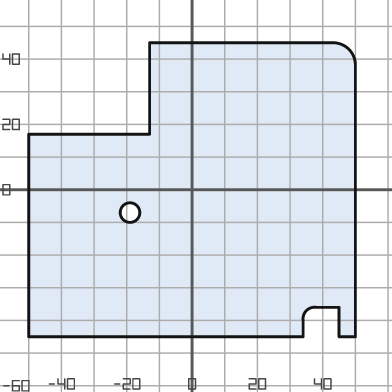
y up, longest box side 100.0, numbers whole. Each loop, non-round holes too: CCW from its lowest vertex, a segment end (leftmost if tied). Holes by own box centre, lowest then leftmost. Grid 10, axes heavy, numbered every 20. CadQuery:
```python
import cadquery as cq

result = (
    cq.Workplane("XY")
    .moveTo(-50.0, -45.0)
    .lineTo(34.0, -45.0)
    .lineTo(34.0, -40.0)
    .threePointArc((35.0, -37.0), (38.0, -36.0))
    .lineTo(45.0, -36.0)
    .lineTo(45.0, -45.0)
    .lineTo(50.0, -45.0)
    .lineTo(50.0, 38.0)
    .threePointArc((48.0, 43.0), (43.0, 45.0))
    .lineTo(-13.0, 45.0)
    .lineTo(-13.0, 17.0)
    .lineTo(-50.0, 17.0)
    .close()
    .moveTo(-19.0, -7.0)
    .circle(3.0)
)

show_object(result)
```